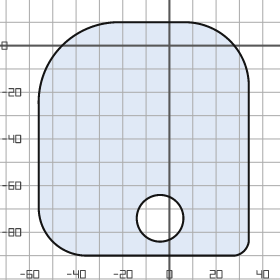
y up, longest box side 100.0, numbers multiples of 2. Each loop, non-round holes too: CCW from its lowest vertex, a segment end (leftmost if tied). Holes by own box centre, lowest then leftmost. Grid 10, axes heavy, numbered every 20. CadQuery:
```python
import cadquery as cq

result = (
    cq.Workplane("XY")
    .moveTo(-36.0, -90.0)
    .lineTo(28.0, -90.0)
    .threePointArc((32.0, -88.0), (34.0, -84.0))
    .lineTo(34.0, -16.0)
    .threePointArc((26.0, 2.0), (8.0, 10.0))
    .lineTo(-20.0, 10.0)
    .threePointArc((-46.0, 0.0), (-56.0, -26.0))
    .lineTo(-56.0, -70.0)
    .threePointArc((-50.0, -84.0), (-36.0, -90.0))
    .close()
    .moveTo(-4.0, -74.0)
    .circle(10.0)
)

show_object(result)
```